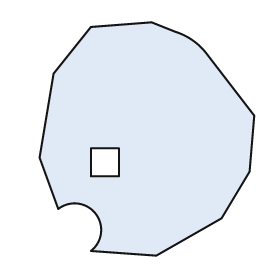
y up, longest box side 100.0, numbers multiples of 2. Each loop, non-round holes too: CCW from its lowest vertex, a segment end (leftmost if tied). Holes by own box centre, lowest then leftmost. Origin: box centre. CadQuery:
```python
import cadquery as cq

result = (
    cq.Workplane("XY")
    .moveTo(4.0, -50.0)
    .lineTo(32.0, -34.0)
    .lineTo(44.0, -14.0)
    .lineTo(46.0, 10.0)
    .lineTo(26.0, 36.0)
    .threePointArc((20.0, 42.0), (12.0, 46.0))
    .lineTo(2.0, 50.0)
    .lineTo(-24.0, 48.0)
    .lineTo(-40.0, 28.0)
    .lineTo(-46.0, -8.0)
    .lineTo(-38.0, -30.0)
    .threePointArc((-22.0, -32.0), (-24.0, -48.0))
    .close()
    .moveTo(-24.0, -16.0)
    .lineTo(-12.0, -16.0)
    .lineTo(-12.0, -4.0)
    .lineTo(-24.0, -4.0)
    .close()
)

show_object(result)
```